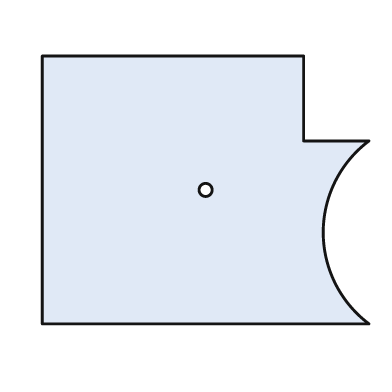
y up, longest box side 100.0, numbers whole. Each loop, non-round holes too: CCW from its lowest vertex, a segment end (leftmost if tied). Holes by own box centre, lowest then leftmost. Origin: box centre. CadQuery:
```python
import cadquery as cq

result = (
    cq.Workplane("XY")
    .moveTo(-50.0, -41.0)
    .lineTo(50.0, -41.0)
    .threePointArc((36.0, -13.0), (50.0, 15.0))
    .lineTo(30.0, 15.0)
    .lineTo(30.0, 41.0)
    .lineTo(-50.0, 41.0)
    .close()
    .moveTo(0.0, 0.0)
    .circle(2.0)
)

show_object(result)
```